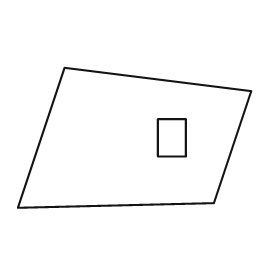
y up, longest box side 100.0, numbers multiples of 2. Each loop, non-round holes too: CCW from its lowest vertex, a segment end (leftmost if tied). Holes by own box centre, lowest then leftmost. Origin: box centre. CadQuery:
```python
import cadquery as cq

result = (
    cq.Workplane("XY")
    .moveTo(-50.0, -30.0)
    .lineTo(34.0, -28.0)
    .lineTo(50.0, 20.0)
    .lineTo(-30.0, 30.0)
    .close()
    .moveTo(10.0, -8.0)
    .lineTo(22.0, -8.0)
    .lineTo(22.0, 8.0)
    .lineTo(10.0, 8.0)
    .close()
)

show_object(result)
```